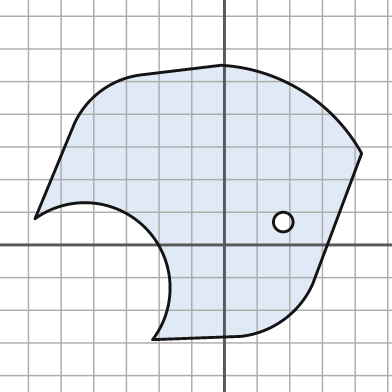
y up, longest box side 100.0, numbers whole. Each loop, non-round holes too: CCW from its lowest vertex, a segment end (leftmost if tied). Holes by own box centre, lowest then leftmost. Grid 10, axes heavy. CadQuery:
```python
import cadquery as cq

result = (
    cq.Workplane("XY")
    .moveTo(-22.0, -29.0)
    .lineTo(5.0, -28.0)
    .threePointArc((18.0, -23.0), (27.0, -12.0))
    .lineTo(42.0, 28.0)
    .threePointArc((24.0, 47.0), (-1.0, 55.0))
    .lineTo(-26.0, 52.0)
    .threePointArc((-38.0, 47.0), (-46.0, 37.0))
    .lineTo(-58.0, 8.0)
    .threePointArc((-24.0, 5.0), (-22.0, -29.0))
    .close()
    .moveTo(18.0, 7.0)
    .circle(3.0)
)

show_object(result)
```